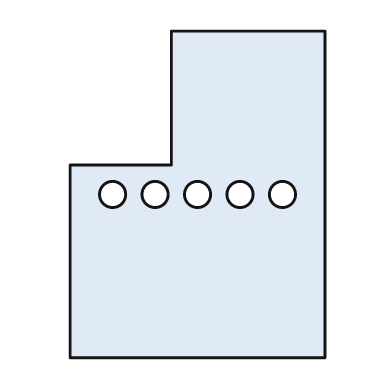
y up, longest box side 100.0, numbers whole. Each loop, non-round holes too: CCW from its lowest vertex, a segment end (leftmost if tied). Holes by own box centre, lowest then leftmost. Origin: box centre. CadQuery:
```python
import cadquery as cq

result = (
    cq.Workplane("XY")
    .moveTo(-39.0, -50.0)
    .lineTo(39.0, -50.0)
    .lineTo(39.0, 50.0)
    .lineTo(-8.0, 50.0)
    .lineTo(-8.0, 9.0)
    .lineTo(-39.0, 9.0)
    .close()
    .moveTo(-26.0, 0.0)
    .circle(4.0)
    .moveTo(-13.0, 0.0)
    .circle(4.0)
    .moveTo(0.0, 0.0)
    .circle(4.0)
    .moveTo(13.0, 0.0)
    .circle(4.0)
    .moveTo(26.0, 0.0)
    .circle(4.0)
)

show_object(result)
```